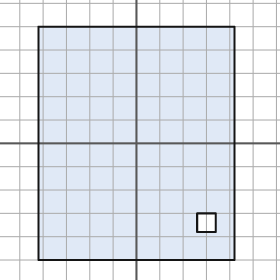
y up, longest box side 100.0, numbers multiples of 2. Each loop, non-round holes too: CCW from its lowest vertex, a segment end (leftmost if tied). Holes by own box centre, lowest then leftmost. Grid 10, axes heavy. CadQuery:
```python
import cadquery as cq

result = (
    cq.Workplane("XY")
    .moveTo(-42.0, -50.0)
    .lineTo(42.0, -50.0)
    .lineTo(42.0, 50.0)
    .lineTo(-42.0, 50.0)
    .close()
    .moveTo(26.0, -38.0)
    .lineTo(34.0, -38.0)
    .lineTo(34.0, -30.0)
    .lineTo(26.0, -30.0)
    .close()
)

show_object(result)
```